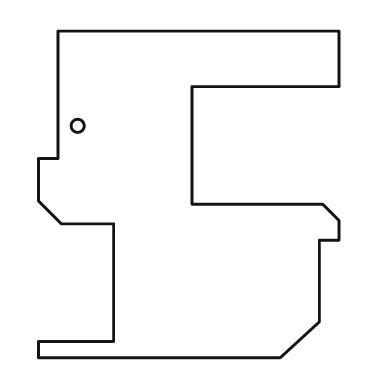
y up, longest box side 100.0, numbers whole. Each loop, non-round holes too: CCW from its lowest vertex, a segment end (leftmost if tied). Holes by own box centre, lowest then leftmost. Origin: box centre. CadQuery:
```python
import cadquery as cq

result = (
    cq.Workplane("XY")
    .moveTo(-46.0, -50.0)
    .lineTo(28.0, -50.0)
    .lineTo(40.0, -39.0)
    .lineTo(40.0, -14.0)
    .lineTo(46.0, -14.0)
    .lineTo(46.0, -8.0)
    .lineTo(41.0, -3.0)
    .lineTo(1.0, -3.0)
    .lineTo(1.0, 33.0)
    .lineTo(46.0, 33.0)
    .lineTo(46.0, 50.0)
    .lineTo(-40.0, 50.0)
    .lineTo(-40.0, 11.0)
    .lineTo(-46.0, 11.0)
    .lineTo(-46.0, -2.0)
    .lineTo(-39.0, -9.0)
    .lineTo(-23.0, -9.0)
    .lineTo(-23.0, -45.0)
    .lineTo(-46.0, -45.0)
    .close()
    .moveTo(-34.0, 21.0)
    .circle(2.0)
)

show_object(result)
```